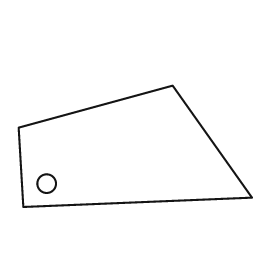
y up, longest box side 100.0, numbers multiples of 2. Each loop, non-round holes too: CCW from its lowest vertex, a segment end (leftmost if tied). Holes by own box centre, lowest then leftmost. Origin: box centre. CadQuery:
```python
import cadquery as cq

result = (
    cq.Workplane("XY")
    .moveTo(-48.0, -26.0)
    .lineTo(50.0, -22.0)
    .lineTo(16.0, 26.0)
    .lineTo(-50.0, 8.0)
    .close()
    .moveTo(-38.0, -16.0)
    .circle(4.0)
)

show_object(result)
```